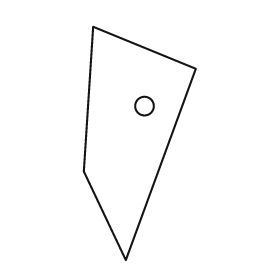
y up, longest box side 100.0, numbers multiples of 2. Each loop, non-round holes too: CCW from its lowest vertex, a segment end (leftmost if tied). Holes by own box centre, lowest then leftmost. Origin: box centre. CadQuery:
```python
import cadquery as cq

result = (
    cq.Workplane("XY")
    .moveTo(-6.0, -50.0)
    .lineTo(24.0, 32.0)
    .lineTo(-20.0, 50.0)
    .lineTo(-24.0, -12.0)
    .close()
    .moveTo(2.0, 16.0)
    .circle(4.0)
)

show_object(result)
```